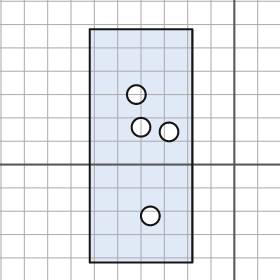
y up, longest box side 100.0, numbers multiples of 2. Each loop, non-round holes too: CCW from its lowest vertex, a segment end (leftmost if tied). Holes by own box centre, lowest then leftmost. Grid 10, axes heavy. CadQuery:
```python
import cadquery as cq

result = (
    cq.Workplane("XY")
    .moveTo(-62.0, -42.0)
    .lineTo(-18.0, -42.0)
    .lineTo(-18.0, 58.0)
    .lineTo(-62.0, 58.0)
    .close()
    .moveTo(-36.0, -22.0)
    .circle(4.0)
    .moveTo(-28.0, 14.0)
    .circle(4.0)
    .moveTo(-40.0, 16.0)
    .circle(4.0)
    .moveTo(-42.0, 30.0)
    .circle(4.0)
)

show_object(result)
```